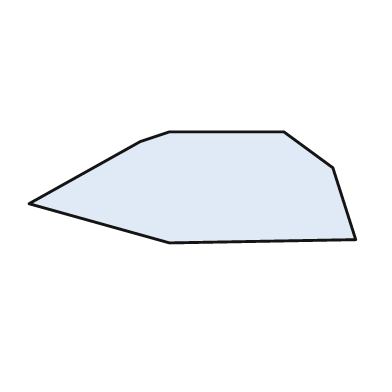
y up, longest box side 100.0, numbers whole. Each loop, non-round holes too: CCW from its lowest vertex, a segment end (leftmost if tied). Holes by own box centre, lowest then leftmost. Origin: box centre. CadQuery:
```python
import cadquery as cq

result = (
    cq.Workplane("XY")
    .moveTo(-7.0, -17.0)
    .lineTo(50.0, -16.0)
    .lineTo(43.0, 6.0)
    .lineTo(28.0, 17.0)
    .lineTo(-7.0, 17.0)
    .lineTo(-16.0, 14.0)
    .lineTo(-50.0, -5.0)
    .close()
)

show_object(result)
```